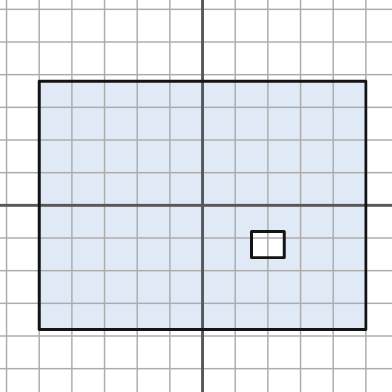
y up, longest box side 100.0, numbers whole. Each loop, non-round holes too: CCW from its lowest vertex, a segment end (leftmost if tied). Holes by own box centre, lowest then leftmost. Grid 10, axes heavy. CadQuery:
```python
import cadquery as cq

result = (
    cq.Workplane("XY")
    .moveTo(-50.0, -38.0)
    .lineTo(50.0, -38.0)
    .lineTo(50.0, 38.0)
    .lineTo(-50.0, 38.0)
    .close()
    .moveTo(15.0, -16.0)
    .lineTo(25.0, -16.0)
    .lineTo(25.0, -8.0)
    .lineTo(15.0, -8.0)
    .close()
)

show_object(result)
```